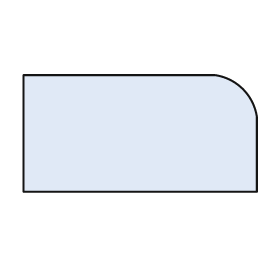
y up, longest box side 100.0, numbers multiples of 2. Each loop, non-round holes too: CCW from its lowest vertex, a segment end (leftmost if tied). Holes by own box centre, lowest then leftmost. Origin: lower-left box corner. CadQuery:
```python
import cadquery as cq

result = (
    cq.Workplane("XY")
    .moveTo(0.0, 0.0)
    .lineTo(100.0, 0.0)
    .lineTo(100.0, 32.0)
    .threePointArc((94.0, 44.0), (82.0, 50.0))
    .lineTo(0.0, 50.0)
    .close()
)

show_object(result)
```